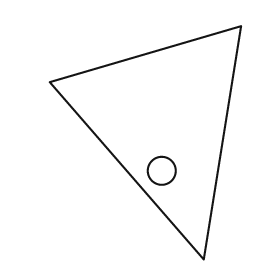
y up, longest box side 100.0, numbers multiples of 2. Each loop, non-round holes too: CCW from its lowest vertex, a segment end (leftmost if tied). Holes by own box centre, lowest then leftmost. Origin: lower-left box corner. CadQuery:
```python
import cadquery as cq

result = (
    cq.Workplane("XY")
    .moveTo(66.0, 0.0)
    .lineTo(82.0, 100.0)
    .lineTo(0.0, 76.0)
    .close()
    .moveTo(48.0, 38.0)
    .circle(6.0)
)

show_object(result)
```